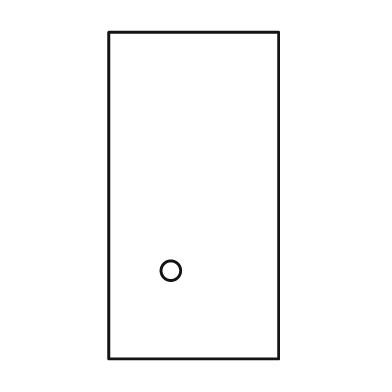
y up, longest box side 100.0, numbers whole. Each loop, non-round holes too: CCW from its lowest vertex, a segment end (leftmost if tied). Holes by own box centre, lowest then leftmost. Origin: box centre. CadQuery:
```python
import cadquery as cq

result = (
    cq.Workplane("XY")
    .moveTo(-26.0, -50.0)
    .lineTo(26.0, -50.0)
    .lineTo(26.0, 50.0)
    .lineTo(-26.0, 50.0)
    .close()
    .moveTo(-7.0, -23.0)
    .circle(3.0)
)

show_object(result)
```